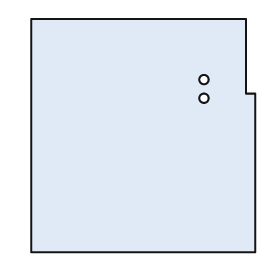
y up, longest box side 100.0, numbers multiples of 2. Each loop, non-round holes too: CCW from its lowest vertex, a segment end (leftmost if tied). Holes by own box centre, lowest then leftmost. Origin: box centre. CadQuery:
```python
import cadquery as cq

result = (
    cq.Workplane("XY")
    .moveTo(-48.0, -50.0)
    .lineTo(48.0, -50.0)
    .lineTo(48.0, 18.0)
    .lineTo(44.0, 18.0)
    .lineTo(44.0, 50.0)
    .lineTo(-48.0, 50.0)
    .close()
    .moveTo(26.0, 16.0)
    .circle(2.0)
    .moveTo(26.0, 24.0)
    .circle(2.0)
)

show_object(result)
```